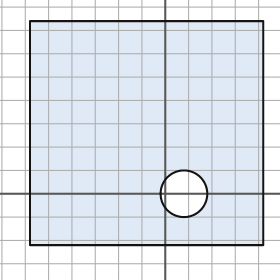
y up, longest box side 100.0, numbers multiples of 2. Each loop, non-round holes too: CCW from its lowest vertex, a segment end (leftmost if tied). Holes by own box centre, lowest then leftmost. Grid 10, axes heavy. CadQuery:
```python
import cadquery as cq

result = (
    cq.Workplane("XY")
    .moveTo(-58.0, -22.0)
    .lineTo(42.0, -22.0)
    .lineTo(42.0, 74.0)
    .lineTo(-58.0, 74.0)
    .close()
    .moveTo(8.0, 0.0)
    .circle(10.0)
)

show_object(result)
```